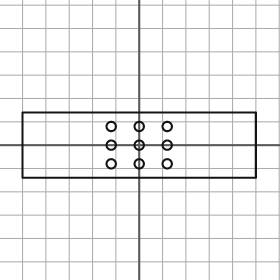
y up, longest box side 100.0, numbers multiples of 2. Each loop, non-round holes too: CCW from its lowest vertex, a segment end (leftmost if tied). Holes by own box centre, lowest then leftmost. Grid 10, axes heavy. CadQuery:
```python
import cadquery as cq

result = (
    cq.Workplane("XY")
    .moveTo(-50.0, -14.0)
    .lineTo(50.0, -14.0)
    .lineTo(50.0, 14.0)
    .lineTo(-50.0, 14.0)
    .close()
    .moveTo(-12.0, -8.0)
    .circle(2.0)
    .moveTo(0.0, -8.0)
    .circle(2.0)
    .moveTo(12.0, -8.0)
    .circle(2.0)
    .moveTo(-12.0, 0.0)
    .circle(2.0)
    .moveTo(0.0, 0.0)
    .circle(2.0)
    .moveTo(12.0, 0.0)
    .circle(2.0)
    .moveTo(-12.0, 8.0)
    .circle(2.0)
    .moveTo(0.0, 8.0)
    .circle(2.0)
    .moveTo(12.0, 8.0)
    .circle(2.0)
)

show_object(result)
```